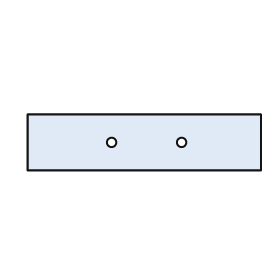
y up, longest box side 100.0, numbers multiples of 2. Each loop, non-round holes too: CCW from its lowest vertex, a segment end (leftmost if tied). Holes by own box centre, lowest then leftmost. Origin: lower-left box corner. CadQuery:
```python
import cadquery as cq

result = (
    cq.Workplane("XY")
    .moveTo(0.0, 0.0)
    .lineTo(100.0, 0.0)
    .lineTo(100.0, 24.0)
    .lineTo(0.0, 24.0)
    .close()
    .moveTo(36.0, 12.0)
    .circle(2.0)
    .moveTo(66.0, 12.0)
    .circle(2.0)
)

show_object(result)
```